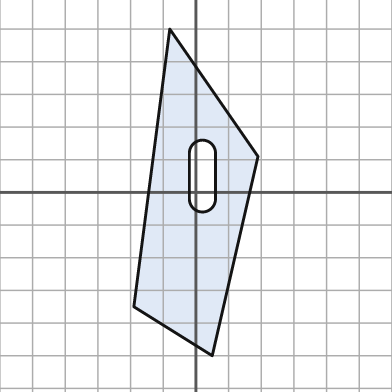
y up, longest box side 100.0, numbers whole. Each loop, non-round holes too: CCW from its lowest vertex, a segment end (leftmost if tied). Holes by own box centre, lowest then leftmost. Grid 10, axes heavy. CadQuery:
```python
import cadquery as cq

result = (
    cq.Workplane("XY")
    .moveTo(5.0, -50.0)
    .lineTo(19.0, 11.0)
    .lineTo(-8.0, 50.0)
    .lineTo(-19.0, -35.0)
    .close()
    .moveTo(-2.0, -2.0)
    .threePointArc((2.0, -6.0), (6.0, -2.0))
    .lineTo(6.0, 12.0)
    .threePointArc((2.0, 16.0), (-2.0, 12.0))
    .close()
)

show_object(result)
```